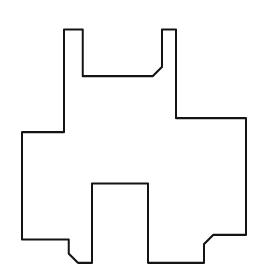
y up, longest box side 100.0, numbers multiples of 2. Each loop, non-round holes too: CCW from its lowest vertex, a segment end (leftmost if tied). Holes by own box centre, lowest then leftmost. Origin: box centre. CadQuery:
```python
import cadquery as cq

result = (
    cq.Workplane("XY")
    .moveTo(-24.0, -50.0)
    .lineTo(-18.0, -50.0)
    .lineTo(-18.0, -16.0)
    .lineTo(6.0, -16.0)
    .lineTo(6.0, -50.0)
    .lineTo(30.0, -50.0)
    .lineTo(30.0, -42.0)
    .lineTo(34.0, -38.0)
    .lineTo(48.0, -38.0)
    .lineTo(48.0, 12.0)
    .lineTo(18.0, 12.0)
    .lineTo(18.0, 50.0)
    .lineTo(12.0, 50.0)
    .lineTo(12.0, 34.0)
    .lineTo(8.0, 30.0)
    .lineTo(-22.0, 30.0)
    .lineTo(-22.0, 50.0)
    .lineTo(-30.0, 50.0)
    .lineTo(-30.0, 6.0)
    .lineTo(-48.0, 6.0)
    .lineTo(-48.0, -40.0)
    .lineTo(-28.0, -40.0)
    .lineTo(-28.0, -46.0)
    .close()
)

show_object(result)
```